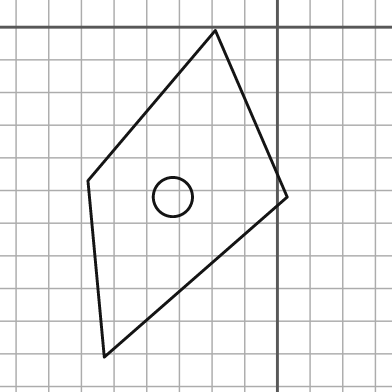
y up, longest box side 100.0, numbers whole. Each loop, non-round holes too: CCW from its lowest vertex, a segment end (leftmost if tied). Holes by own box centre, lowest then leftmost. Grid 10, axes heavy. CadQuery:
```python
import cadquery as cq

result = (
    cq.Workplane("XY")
    .moveTo(-53.0, -101.0)
    .lineTo(3.0, -52.0)
    .lineTo(-19.0, -1.0)
    .lineTo(-58.0, -47.0)
    .close()
    .moveTo(-32.0, -52.0)
    .circle(6.0)
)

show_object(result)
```